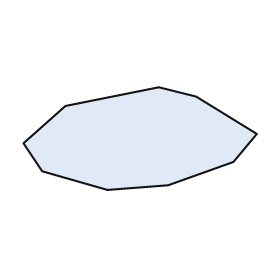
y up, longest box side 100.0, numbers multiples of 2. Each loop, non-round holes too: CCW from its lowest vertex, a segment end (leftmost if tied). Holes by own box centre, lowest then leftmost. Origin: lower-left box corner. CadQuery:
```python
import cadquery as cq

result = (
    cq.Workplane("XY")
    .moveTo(36.0, 0.0)
    .lineTo(62.0, 2.0)
    .lineTo(90.0, 12.0)
    .lineTo(100.0, 24.0)
    .lineTo(74.0, 40.0)
    .lineTo(58.0, 44.0)
    .lineTo(18.0, 36.0)
    .lineTo(0.0, 20.0)
    .lineTo(8.0, 8.0)
    .close()
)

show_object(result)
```